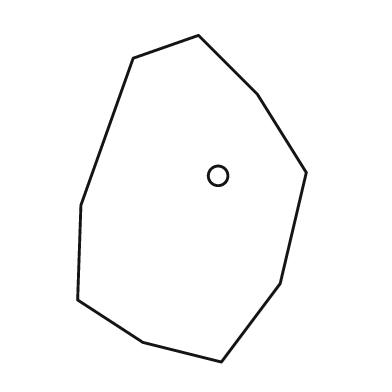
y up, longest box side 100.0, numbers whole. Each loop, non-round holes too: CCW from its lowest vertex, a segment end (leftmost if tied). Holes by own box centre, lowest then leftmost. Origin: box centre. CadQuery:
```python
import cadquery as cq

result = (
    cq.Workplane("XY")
    .moveTo(9.0, -50.0)
    .lineTo(27.0, -26.0)
    .lineTo(35.0, 8.0)
    .lineTo(20.0, 32.0)
    .lineTo(2.0, 50.0)
    .lineTo(-18.0, 43.0)
    .lineTo(-34.0, -2.0)
    .lineTo(-35.0, -31.0)
    .lineTo(-15.0, -44.0)
    .close()
    .moveTo(8.0, 7.0)
    .circle(3.0)
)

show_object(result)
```